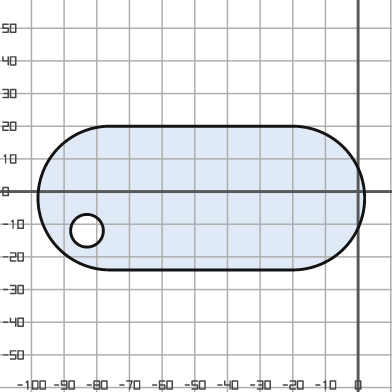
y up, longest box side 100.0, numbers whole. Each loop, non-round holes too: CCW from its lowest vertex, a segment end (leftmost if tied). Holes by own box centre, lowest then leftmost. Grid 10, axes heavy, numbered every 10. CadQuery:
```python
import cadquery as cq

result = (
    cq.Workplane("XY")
    .moveTo(-76.0, -24.0)
    .lineTo(-20.0, -24.0)
    .threePointArc((2.0, -2.0), (-20.0, 20.0))
    .lineTo(-76.0, 20.0)
    .threePointArc((-98.0, -2.0), (-76.0, -24.0))
    .close()
    .moveTo(-83.0, -12.0)
    .circle(5.0)
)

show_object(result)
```